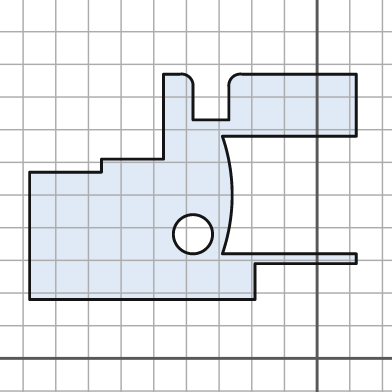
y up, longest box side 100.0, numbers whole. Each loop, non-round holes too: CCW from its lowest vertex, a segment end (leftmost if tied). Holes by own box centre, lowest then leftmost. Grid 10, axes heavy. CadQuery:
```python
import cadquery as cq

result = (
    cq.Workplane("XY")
    .moveTo(-88.0, 18.0)
    .lineTo(-19.0, 18.0)
    .lineTo(-19.0, 29.0)
    .lineTo(12.0, 29.0)
    .lineTo(12.0, 32.0)
    .lineTo(-29.0, 32.0)
    .threePointArc((-26.0, 50.0), (-29.0, 68.0))
    .lineTo(12.0, 68.0)
    .lineTo(12.0, 87.0)
    .lineTo(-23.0, 87.0)
    .threePointArc((-26.0, 86.0), (-27.0, 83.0))
    .lineTo(-27.0, 73.0)
    .lineTo(-38.0, 73.0)
    .lineTo(-38.0, 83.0)
    .threePointArc((-39.0, 86.0), (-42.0, 87.0))
    .lineTo(-47.0, 87.0)
    .lineTo(-47.0, 61.0)
    .lineTo(-66.0, 61.0)
    .lineTo(-66.0, 57.0)
    .lineTo(-88.0, 57.0)
    .close()
    .moveTo(-38.0, 38.0)
    .circle(6.0)
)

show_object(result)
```